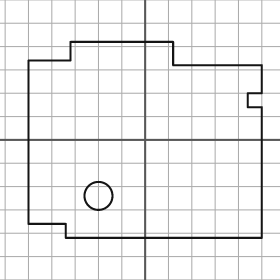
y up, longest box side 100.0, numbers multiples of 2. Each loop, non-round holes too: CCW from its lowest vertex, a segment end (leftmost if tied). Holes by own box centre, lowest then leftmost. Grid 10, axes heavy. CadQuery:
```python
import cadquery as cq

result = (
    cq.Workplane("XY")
    .moveTo(-34.0, -42.0)
    .lineTo(50.0, -42.0)
    .lineTo(50.0, 14.0)
    .lineTo(44.0, 14.0)
    .lineTo(44.0, 20.0)
    .lineTo(50.0, 20.0)
    .lineTo(50.0, 32.0)
    .lineTo(12.0, 32.0)
    .lineTo(12.0, 42.0)
    .lineTo(-32.0, 42.0)
    .lineTo(-32.0, 34.0)
    .lineTo(-50.0, 34.0)
    .lineTo(-50.0, -36.0)
    .lineTo(-34.0, -36.0)
    .close()
    .moveTo(-20.0, -24.0)
    .circle(6.0)
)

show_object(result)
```